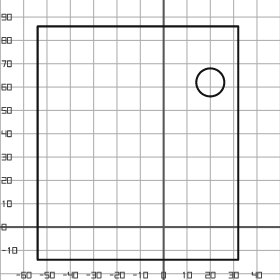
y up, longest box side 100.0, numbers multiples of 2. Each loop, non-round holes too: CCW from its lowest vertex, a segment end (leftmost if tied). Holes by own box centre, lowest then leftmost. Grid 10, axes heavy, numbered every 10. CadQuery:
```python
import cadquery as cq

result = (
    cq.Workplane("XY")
    .moveTo(-54.0, -14.0)
    .lineTo(32.0, -14.0)
    .lineTo(32.0, 86.0)
    .lineTo(-54.0, 86.0)
    .close()
    .moveTo(20.0, 62.0)
    .circle(6.0)
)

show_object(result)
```